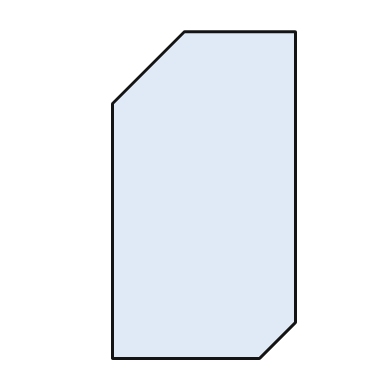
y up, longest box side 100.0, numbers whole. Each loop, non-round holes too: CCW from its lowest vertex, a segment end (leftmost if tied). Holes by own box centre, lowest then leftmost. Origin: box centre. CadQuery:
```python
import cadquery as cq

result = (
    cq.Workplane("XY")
    .moveTo(-28.0, -50.0)
    .lineTo(17.0, -50.0)
    .lineTo(28.0, -39.0)
    .lineTo(28.0, 50.0)
    .lineTo(-6.0, 50.0)
    .lineTo(-28.0, 28.0)
    .close()
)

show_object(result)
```